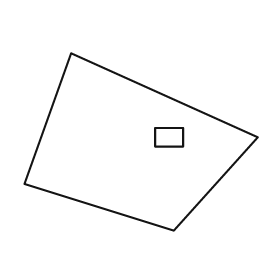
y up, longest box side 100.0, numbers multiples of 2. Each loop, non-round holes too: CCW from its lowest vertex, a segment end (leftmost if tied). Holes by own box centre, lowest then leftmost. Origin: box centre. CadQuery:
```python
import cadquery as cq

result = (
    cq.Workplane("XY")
    .moveTo(14.0, -38.0)
    .lineTo(50.0, 2.0)
    .lineTo(-30.0, 38.0)
    .lineTo(-50.0, -18.0)
    .close()
    .moveTo(6.0, -2.0)
    .lineTo(18.0, -2.0)
    .lineTo(18.0, 6.0)
    .lineTo(6.0, 6.0)
    .close()
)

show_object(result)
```